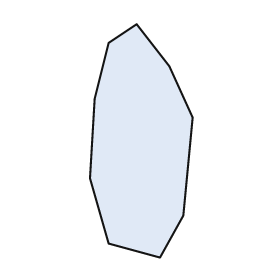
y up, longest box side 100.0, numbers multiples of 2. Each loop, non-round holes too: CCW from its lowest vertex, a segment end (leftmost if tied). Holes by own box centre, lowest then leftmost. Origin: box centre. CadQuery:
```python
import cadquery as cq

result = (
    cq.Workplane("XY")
    .moveTo(8.0, -50.0)
    .lineTo(18.0, -32.0)
    .lineTo(22.0, 10.0)
    .lineTo(12.0, 32.0)
    .lineTo(-2.0, 50.0)
    .lineTo(-14.0, 42.0)
    .lineTo(-20.0, 18.0)
    .lineTo(-22.0, -16.0)
    .lineTo(-14.0, -44.0)
    .close()
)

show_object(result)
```